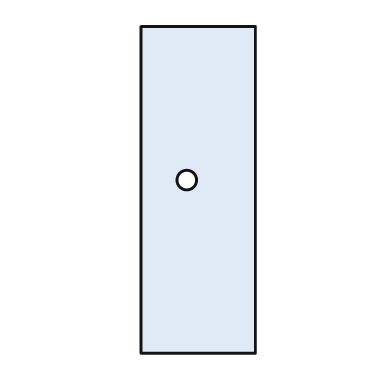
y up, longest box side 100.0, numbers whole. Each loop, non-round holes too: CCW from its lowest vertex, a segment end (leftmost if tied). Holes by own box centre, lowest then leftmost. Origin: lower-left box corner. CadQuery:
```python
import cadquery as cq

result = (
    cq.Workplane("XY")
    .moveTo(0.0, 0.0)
    .lineTo(35.0, 0.0)
    .lineTo(35.0, 100.0)
    .lineTo(0.0, 100.0)
    .close()
    .moveTo(14.0, 53.0)
    .circle(3.0)
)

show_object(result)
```